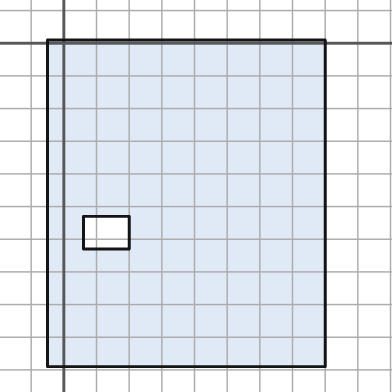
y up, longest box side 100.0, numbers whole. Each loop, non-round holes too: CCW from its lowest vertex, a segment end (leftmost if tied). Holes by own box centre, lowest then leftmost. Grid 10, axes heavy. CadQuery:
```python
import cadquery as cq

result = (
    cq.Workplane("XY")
    .moveTo(-5.0, -99.0)
    .lineTo(80.0, -99.0)
    .lineTo(80.0, 1.0)
    .lineTo(-5.0, 1.0)
    .close()
    .moveTo(6.0, -63.0)
    .lineTo(20.0, -63.0)
    .lineTo(20.0, -53.0)
    .lineTo(6.0, -53.0)
    .close()
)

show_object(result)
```